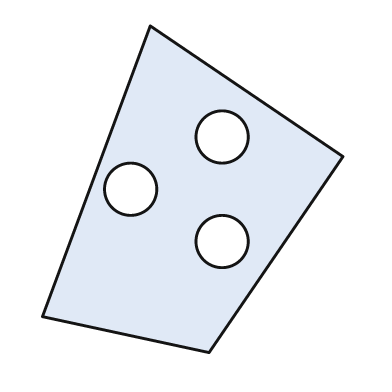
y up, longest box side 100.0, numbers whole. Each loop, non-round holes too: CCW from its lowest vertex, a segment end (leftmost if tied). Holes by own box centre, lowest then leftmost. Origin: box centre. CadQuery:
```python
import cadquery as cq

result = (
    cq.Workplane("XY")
    .moveTo(5.0, -50.0)
    .lineTo(46.0, 10.0)
    .lineTo(-13.0, 50.0)
    .lineTo(-46.0, -39.0)
    .close()
    .moveTo(9.0, -16.0)
    .circle(8.0)
    .moveTo(-19.0, 0.0)
    .circle(8.0)
    .moveTo(9.0, 16.0)
    .circle(8.0)
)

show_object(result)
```